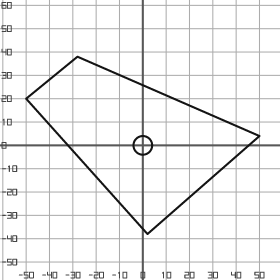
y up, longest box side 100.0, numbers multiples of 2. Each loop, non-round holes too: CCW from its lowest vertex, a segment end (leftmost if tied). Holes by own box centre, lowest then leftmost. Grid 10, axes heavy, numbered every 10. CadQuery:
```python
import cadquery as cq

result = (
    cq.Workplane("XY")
    .moveTo(2.0, -38.0)
    .lineTo(50.0, 4.0)
    .lineTo(-28.0, 38.0)
    .lineTo(-50.0, 20.0)
    .close()
    .moveTo(0.0, 0.0)
    .circle(4.0)
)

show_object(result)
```